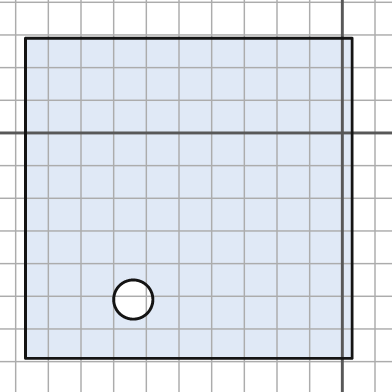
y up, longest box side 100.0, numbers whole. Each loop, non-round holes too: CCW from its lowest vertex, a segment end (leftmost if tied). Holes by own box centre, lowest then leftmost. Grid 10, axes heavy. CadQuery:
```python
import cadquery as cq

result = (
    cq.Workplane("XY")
    .moveTo(-97.0, -69.0)
    .lineTo(3.0, -69.0)
    .lineTo(3.0, 29.0)
    .lineTo(-97.0, 29.0)
    .close()
    .moveTo(-64.0, -51.0)
    .circle(6.0)
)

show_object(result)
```